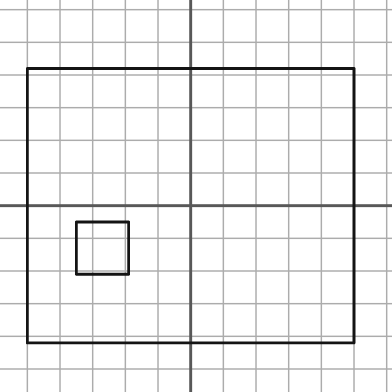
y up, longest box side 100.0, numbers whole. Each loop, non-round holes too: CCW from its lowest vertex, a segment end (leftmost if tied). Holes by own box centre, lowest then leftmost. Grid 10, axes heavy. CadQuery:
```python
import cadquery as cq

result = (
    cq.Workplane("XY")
    .moveTo(-50.0, -42.0)
    .lineTo(50.0, -42.0)
    .lineTo(50.0, 42.0)
    .lineTo(-50.0, 42.0)
    .close()
    .moveTo(-35.0, -21.0)
    .lineTo(-19.0, -21.0)
    .lineTo(-19.0, -5.0)
    .lineTo(-35.0, -5.0)
    .close()
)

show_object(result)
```